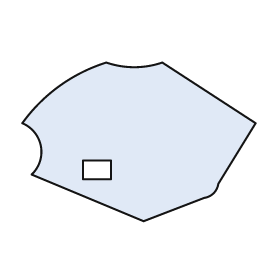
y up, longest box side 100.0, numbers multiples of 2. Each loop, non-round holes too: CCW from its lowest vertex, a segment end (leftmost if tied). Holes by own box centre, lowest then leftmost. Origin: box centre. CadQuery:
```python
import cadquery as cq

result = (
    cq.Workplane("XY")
    .moveTo(2.0, -34.0)
    .lineTo(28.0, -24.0)
    .threePointArc((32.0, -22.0), (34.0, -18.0))
    .lineTo(50.0, 8.0)
    .lineTo(10.0, 34.0)
    .threePointArc((-2.0, 32.0), (-14.0, 34.0))
    .threePointArc((-34.0, 24.0), (-50.0, 8.0))
    .threePointArc((-42.0, -2.0), (-46.0, -14.0))
    .close()
    .moveTo(-24.0, -16.0)
    .lineTo(-12.0, -16.0)
    .lineTo(-12.0, -8.0)
    .lineTo(-24.0, -8.0)
    .close()
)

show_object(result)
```